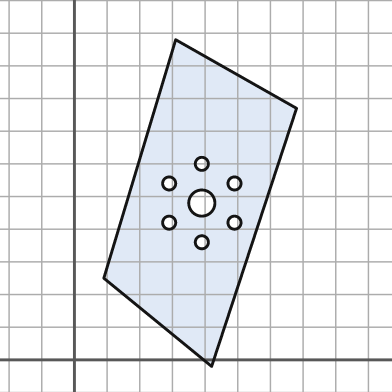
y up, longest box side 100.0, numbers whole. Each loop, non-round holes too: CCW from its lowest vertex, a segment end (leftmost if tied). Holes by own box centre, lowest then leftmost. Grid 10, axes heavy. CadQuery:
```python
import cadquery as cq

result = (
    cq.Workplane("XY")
    .moveTo(42.0, -2.0)
    .lineTo(68.0, 77.0)
    .lineTo(31.0, 98.0)
    .lineTo(9.0, 25.0)
    .close()
    .moveTo(39.0, 36.0)
    .circle(2.0)
    .moveTo(29.0, 42.0)
    .circle(2.0)
    .moveTo(49.0, 42.0)
    .circle(2.0)
    .moveTo(39.0, 48.0)
    .circle(4.0)
    .moveTo(29.0, 54.0)
    .circle(2.0)
    .moveTo(49.0, 54.0)
    .circle(2.0)
    .moveTo(39.0, 60.0)
    .circle(2.0)
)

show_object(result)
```